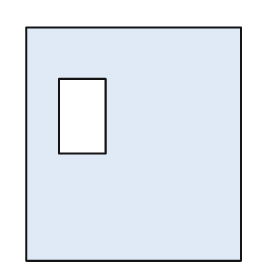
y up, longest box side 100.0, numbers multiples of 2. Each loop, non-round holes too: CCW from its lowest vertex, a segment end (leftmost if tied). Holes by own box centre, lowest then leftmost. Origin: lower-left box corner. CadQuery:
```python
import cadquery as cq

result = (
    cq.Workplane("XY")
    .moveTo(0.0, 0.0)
    .lineTo(92.0, 0.0)
    .lineTo(92.0, 100.0)
    .lineTo(0.0, 100.0)
    .close()
    .moveTo(14.0, 46.0)
    .lineTo(34.0, 46.0)
    .lineTo(34.0, 78.0)
    .lineTo(14.0, 78.0)
    .close()
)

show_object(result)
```